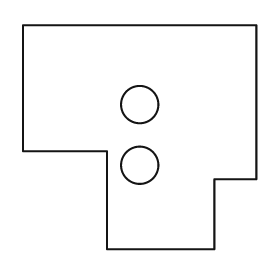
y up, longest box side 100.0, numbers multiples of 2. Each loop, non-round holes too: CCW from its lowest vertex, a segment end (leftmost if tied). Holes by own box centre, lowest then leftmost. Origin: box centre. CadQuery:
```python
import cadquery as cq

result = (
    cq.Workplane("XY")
    .moveTo(-14.0, -48.0)
    .lineTo(32.0, -48.0)
    .lineTo(32.0, -18.0)
    .lineTo(50.0, -18.0)
    .lineTo(50.0, 48.0)
    .lineTo(-50.0, 48.0)
    .lineTo(-50.0, -6.0)
    .lineTo(-14.0, -6.0)
    .close()
    .moveTo(0.0, -12.0)
    .circle(8.0)
    .moveTo(0.0, 14.0)
    .circle(8.0)
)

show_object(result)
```